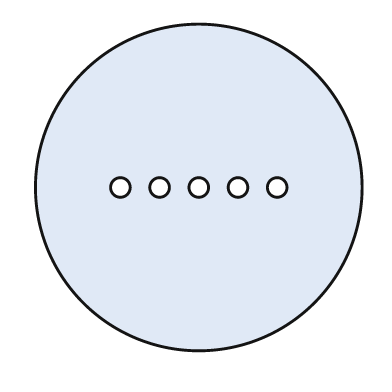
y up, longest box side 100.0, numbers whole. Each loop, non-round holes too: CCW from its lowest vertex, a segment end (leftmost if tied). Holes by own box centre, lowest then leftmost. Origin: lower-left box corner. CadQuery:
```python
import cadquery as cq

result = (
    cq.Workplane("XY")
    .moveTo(50.0, 50.0)
    .circle(50.0)
    .moveTo(26.0, 50.0)
    .circle(3.0)
    .moveTo(38.0, 50.0)
    .circle(3.0)
    .moveTo(50.0, 50.0)
    .circle(3.0)
    .moveTo(62.0, 50.0)
    .circle(3.0)
    .moveTo(74.0, 50.0)
    .circle(3.0)
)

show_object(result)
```